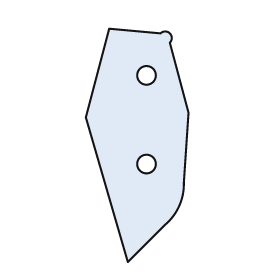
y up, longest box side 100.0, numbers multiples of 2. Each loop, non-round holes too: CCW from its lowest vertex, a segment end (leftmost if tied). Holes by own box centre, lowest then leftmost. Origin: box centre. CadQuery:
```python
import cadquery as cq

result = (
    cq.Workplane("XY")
    .moveTo(-4.0, -50.0)
    .lineTo(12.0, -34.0)
    .threePointArc((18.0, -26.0), (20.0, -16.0))
    .lineTo(22.0, 14.0)
    .lineTo(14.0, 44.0)
    .threePointArc((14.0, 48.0), (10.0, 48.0))
    .lineTo(-12.0, 50.0)
    .lineTo(-22.0, 12.0)
    .close()
    .moveTo(4.0, -8.0)
    .circle(4.0)
    .moveTo(4.0, 30.0)
    .circle(4.0)
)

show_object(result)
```